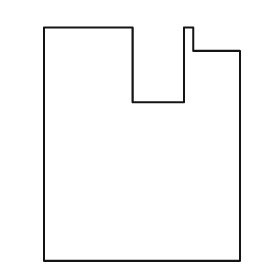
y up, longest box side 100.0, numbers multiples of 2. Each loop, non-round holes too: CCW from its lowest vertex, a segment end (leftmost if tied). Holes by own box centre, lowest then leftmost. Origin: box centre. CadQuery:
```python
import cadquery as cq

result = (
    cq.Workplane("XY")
    .moveTo(-42.0, -50.0)
    .lineTo(42.0, -50.0)
    .lineTo(42.0, 40.0)
    .lineTo(22.0, 40.0)
    .lineTo(22.0, 50.0)
    .lineTo(18.0, 50.0)
    .lineTo(18.0, 18.0)
    .lineTo(-4.0, 18.0)
    .lineTo(-4.0, 50.0)
    .lineTo(-42.0, 50.0)
    .close()
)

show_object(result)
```